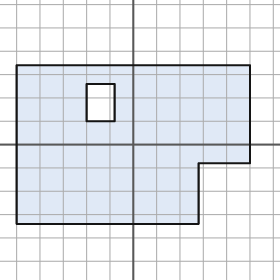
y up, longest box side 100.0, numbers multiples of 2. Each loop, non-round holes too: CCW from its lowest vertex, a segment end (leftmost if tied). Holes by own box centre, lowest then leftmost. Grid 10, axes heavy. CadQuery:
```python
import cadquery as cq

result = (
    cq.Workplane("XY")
    .moveTo(-50.0, -34.0)
    .lineTo(28.0, -34.0)
    .lineTo(28.0, -8.0)
    .lineTo(50.0, -8.0)
    .lineTo(50.0, 34.0)
    .lineTo(-50.0, 34.0)
    .close()
    .moveTo(-20.0, 10.0)
    .lineTo(-8.0, 10.0)
    .lineTo(-8.0, 26.0)
    .lineTo(-20.0, 26.0)
    .close()
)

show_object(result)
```